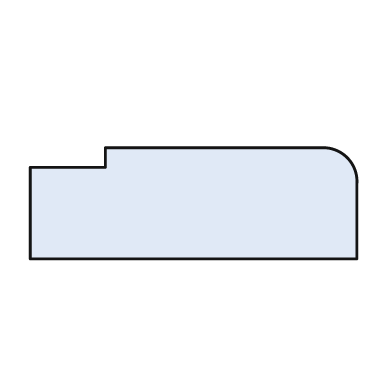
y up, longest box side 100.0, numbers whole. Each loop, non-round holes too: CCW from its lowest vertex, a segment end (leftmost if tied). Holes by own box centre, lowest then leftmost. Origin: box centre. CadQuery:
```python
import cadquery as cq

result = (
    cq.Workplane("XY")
    .moveTo(-50.0, -17.0)
    .lineTo(50.0, -17.0)
    .lineTo(50.0, 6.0)
    .threePointArc((47.0, 14.0), (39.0, 17.0))
    .lineTo(-27.0, 17.0)
    .lineTo(-27.0, 11.0)
    .lineTo(-50.0, 11.0)
    .close()
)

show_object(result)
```